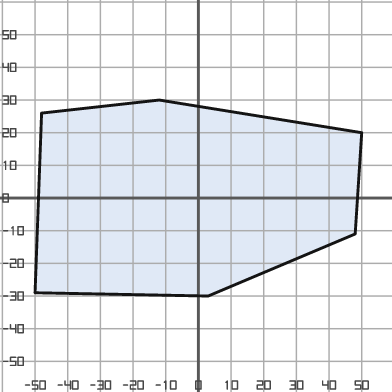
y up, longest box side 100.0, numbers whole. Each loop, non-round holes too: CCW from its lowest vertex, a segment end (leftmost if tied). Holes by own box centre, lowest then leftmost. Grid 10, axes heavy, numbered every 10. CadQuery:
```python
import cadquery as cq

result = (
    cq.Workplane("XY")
    .moveTo(3.0, -30.0)
    .lineTo(48.0, -11.0)
    .lineTo(50.0, 20.0)
    .lineTo(-12.0, 30.0)
    .lineTo(-48.0, 26.0)
    .lineTo(-50.0, -29.0)
    .close()
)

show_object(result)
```